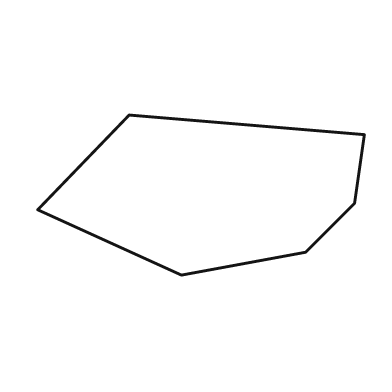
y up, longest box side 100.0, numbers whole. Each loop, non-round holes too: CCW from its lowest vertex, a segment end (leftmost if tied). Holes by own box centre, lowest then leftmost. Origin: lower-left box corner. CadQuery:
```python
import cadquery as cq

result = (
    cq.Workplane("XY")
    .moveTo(44.0, 0.0)
    .lineTo(82.0, 7.0)
    .lineTo(97.0, 22.0)
    .lineTo(100.0, 43.0)
    .lineTo(28.0, 49.0)
    .lineTo(0.0, 20.0)
    .close()
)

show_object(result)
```